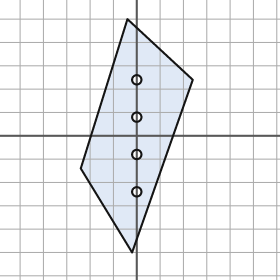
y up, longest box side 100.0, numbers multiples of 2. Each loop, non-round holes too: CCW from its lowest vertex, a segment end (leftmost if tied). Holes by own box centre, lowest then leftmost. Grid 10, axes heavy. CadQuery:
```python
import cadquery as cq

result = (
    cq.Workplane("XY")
    .moveTo(-2.0, -50.0)
    .lineTo(24.0, 24.0)
    .lineTo(-4.0, 50.0)
    .lineTo(-24.0, -14.0)
    .close()
    .moveTo(0.0, -24.0)
    .circle(2.0)
    .moveTo(0.0, -8.0)
    .circle(2.0)
    .moveTo(0.0, 8.0)
    .circle(2.0)
    .moveTo(0.0, 24.0)
    .circle(2.0)
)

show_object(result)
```